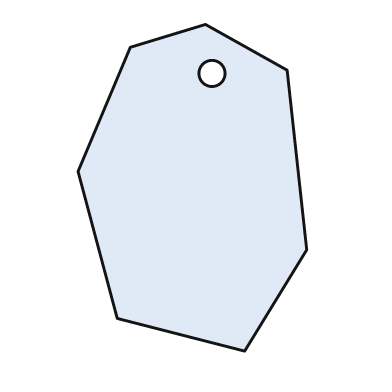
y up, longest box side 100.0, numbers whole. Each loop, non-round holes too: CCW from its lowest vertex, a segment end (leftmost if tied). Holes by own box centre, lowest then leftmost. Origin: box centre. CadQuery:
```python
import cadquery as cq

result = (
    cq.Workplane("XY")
    .moveTo(16.0, -50.0)
    .lineTo(35.0, -19.0)
    .lineTo(29.0, 36.0)
    .lineTo(4.0, 50.0)
    .lineTo(-19.0, 43.0)
    .lineTo(-35.0, 5.0)
    .lineTo(-23.0, -40.0)
    .close()
    .moveTo(6.0, 35.0)
    .circle(4.0)
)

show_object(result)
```